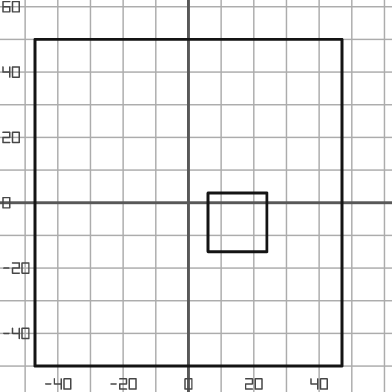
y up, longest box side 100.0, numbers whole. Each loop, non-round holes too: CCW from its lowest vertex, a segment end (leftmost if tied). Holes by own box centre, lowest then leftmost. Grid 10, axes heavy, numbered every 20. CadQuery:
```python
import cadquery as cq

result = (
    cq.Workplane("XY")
    .moveTo(-47.0, -50.0)
    .lineTo(47.0, -50.0)
    .lineTo(47.0, 50.0)
    .lineTo(-47.0, 50.0)
    .close()
    .moveTo(6.0, -15.0)
    .lineTo(24.0, -15.0)
    .lineTo(24.0, 3.0)
    .lineTo(6.0, 3.0)
    .close()
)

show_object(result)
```